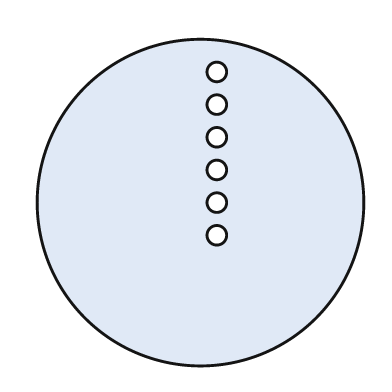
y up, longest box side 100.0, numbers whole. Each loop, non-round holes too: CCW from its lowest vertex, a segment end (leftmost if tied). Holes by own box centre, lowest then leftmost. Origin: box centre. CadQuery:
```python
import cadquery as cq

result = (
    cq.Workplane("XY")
    .moveTo(0.0, 0.0)
    .circle(50.0)
    .moveTo(5.0, -10.0)
    .circle(3.0)
    .moveTo(5.0, 0.0)
    .circle(3.0)
    .moveTo(5.0, 10.0)
    .circle(3.0)
    .moveTo(5.0, 20.0)
    .circle(3.0)
    .moveTo(5.0, 30.0)
    .circle(3.0)
    .moveTo(5.0, 40.0)
    .circle(3.0)
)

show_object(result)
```